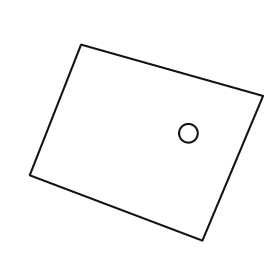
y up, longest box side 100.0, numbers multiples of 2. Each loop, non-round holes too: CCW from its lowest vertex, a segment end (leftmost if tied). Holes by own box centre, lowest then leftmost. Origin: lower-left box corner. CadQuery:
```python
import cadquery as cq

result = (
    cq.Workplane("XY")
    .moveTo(74.0, 0.0)
    .lineTo(100.0, 62.0)
    .lineTo(22.0, 84.0)
    .lineTo(0.0, 28.0)
    .close()
    .moveTo(68.0, 46.0)
    .circle(4.0)
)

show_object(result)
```